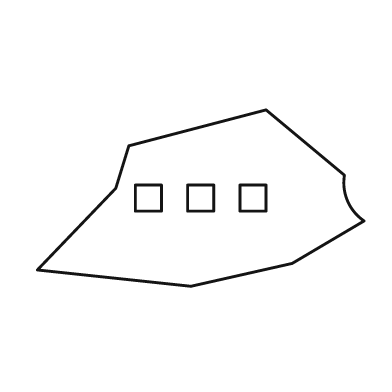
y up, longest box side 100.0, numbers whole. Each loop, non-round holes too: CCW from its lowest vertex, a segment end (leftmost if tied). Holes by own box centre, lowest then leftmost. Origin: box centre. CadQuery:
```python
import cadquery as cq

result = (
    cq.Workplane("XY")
    .moveTo(-3.0, -27.0)
    .lineTo(28.0, -20.0)
    .lineTo(50.0, -7.0)
    .threePointArc((45.0, -1.0), (44.0, 7.0))
    .lineTo(20.0, 27.0)
    .lineTo(-22.0, 16.0)
    .lineTo(-26.0, 3.0)
    .lineTo(-50.0, -22.0)
    .close()
    .moveTo(-20.0, -4.0)
    .lineTo(-12.0, -4.0)
    .lineTo(-12.0, 4.0)
    .lineTo(-20.0, 4.0)
    .close()
    .moveTo(-4.0, -4.0)
    .lineTo(4.0, -4.0)
    .lineTo(4.0, 4.0)
    .lineTo(-4.0, 4.0)
    .close()
    .moveTo(12.0, -4.0)
    .lineTo(20.0, -4.0)
    .lineTo(20.0, 4.0)
    .lineTo(12.0, 4.0)
    .close()
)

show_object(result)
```